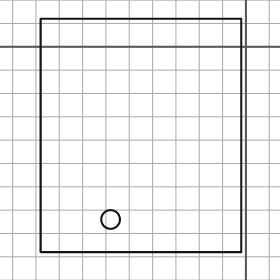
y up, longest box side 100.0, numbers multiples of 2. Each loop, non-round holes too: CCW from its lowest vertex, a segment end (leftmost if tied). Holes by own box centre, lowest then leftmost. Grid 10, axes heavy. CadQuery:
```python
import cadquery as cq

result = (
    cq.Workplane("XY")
    .moveTo(-88.0, -88.0)
    .lineTo(-2.0, -88.0)
    .lineTo(-2.0, 12.0)
    .lineTo(-88.0, 12.0)
    .close()
    .moveTo(-58.0, -74.0)
    .circle(4.0)
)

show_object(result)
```